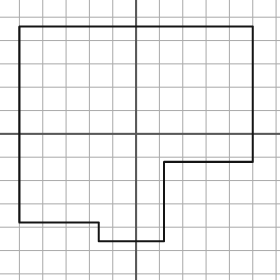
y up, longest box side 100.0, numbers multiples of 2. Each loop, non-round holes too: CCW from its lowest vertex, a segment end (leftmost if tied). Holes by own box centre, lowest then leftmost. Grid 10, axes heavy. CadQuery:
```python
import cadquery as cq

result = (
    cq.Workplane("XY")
    .moveTo(-16.0, -46.0)
    .lineTo(12.0, -46.0)
    .lineTo(12.0, -12.0)
    .lineTo(50.0, -12.0)
    .lineTo(50.0, 46.0)
    .lineTo(-50.0, 46.0)
    .lineTo(-50.0, -38.0)
    .lineTo(-16.0, -38.0)
    .close()
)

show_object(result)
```